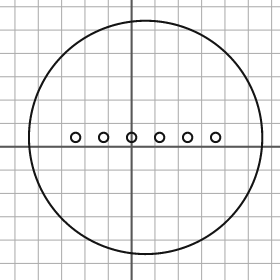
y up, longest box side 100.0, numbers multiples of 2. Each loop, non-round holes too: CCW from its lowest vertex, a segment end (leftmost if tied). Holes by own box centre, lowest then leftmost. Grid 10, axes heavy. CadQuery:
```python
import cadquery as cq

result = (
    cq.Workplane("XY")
    .moveTo(6.0, 4.0)
    .circle(50.0)
    .moveTo(-24.0, 4.0)
    .circle(2.0)
    .moveTo(-12.0, 4.0)
    .circle(2.0)
    .moveTo(0.0, 4.0)
    .circle(2.0)
    .moveTo(12.0, 4.0)
    .circle(2.0)
    .moveTo(24.0, 4.0)
    .circle(2.0)
    .moveTo(36.0, 4.0)
    .circle(2.0)
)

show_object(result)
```